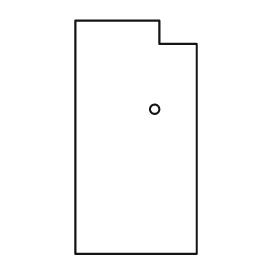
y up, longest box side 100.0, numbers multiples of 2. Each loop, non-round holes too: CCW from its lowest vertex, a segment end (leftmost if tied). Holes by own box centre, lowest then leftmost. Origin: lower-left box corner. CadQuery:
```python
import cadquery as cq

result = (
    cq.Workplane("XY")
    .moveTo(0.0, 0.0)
    .lineTo(52.0, 0.0)
    .lineTo(52.0, 90.0)
    .lineTo(36.0, 90.0)
    .lineTo(36.0, 100.0)
    .lineTo(0.0, 100.0)
    .close()
    .moveTo(34.0, 62.0)
    .circle(2.0)
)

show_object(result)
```